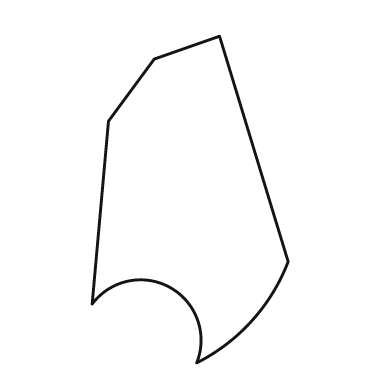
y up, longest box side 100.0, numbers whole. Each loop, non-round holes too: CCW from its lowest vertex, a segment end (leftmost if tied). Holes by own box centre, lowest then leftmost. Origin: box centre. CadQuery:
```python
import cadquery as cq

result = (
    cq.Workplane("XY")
    .moveTo(2.0, -50.0)
    .threePointArc((19.0, -37.0), (30.0, -19.0))
    .lineTo(9.0, 50.0)
    .lineTo(-11.0, 43.0)
    .lineTo(-25.0, 24.0)
    .lineTo(-30.0, -32.0)
    .threePointArc((-6.0, -27.0), (2.0, -50.0))
    .close()
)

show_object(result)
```